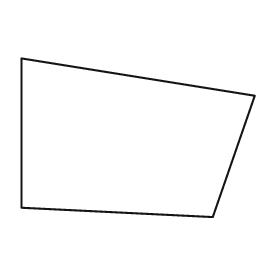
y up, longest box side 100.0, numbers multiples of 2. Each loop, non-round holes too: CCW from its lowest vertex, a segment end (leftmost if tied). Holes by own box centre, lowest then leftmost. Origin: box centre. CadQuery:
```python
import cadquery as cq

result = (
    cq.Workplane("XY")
    .moveTo(32.0, -34.0)
    .lineTo(50.0, 18.0)
    .lineTo(-50.0, 34.0)
    .lineTo(-50.0, -30.0)
    .close()
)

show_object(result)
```